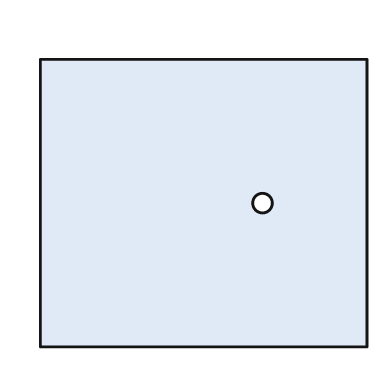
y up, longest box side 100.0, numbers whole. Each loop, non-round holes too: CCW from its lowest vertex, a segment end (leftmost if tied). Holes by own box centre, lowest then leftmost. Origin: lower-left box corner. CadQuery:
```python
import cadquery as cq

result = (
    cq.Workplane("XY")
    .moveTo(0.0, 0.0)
    .lineTo(100.0, 0.0)
    .lineTo(100.0, 88.0)
    .lineTo(0.0, 88.0)
    .close()
    .moveTo(68.0, 44.0)
    .circle(3.0)
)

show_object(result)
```